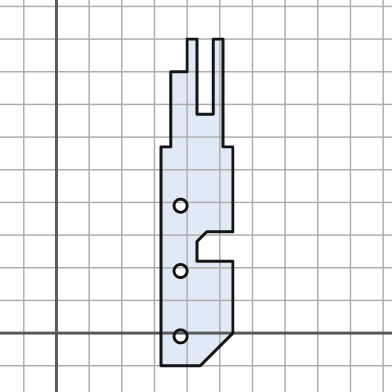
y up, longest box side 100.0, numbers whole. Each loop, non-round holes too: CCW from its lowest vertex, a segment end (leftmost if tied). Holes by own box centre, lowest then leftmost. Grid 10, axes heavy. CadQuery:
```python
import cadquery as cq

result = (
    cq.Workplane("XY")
    .moveTo(32.0, -10.0)
    .lineTo(44.0, -10.0)
    .lineTo(54.0, 0.0)
    .lineTo(54.0, 22.0)
    .lineTo(43.0, 22.0)
    .lineTo(43.0, 28.0)
    .lineTo(46.0, 31.0)
    .lineTo(54.0, 31.0)
    .lineTo(54.0, 57.0)
    .lineTo(51.0, 57.0)
    .lineTo(51.0, 90.0)
    .lineTo(48.0, 90.0)
    .lineTo(48.0, 67.0)
    .lineTo(43.0, 67.0)
    .lineTo(43.0, 90.0)
    .lineTo(40.0, 90.0)
    .lineTo(40.0, 80.0)
    .lineTo(35.0, 80.0)
    .lineTo(35.0, 57.0)
    .lineTo(32.0, 57.0)
    .close()
    .moveTo(38.0, -1.0)
    .circle(2.0)
    .moveTo(38.0, 19.0)
    .circle(2.0)
    .moveTo(38.0, 39.0)
    .circle(2.0)
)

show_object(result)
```